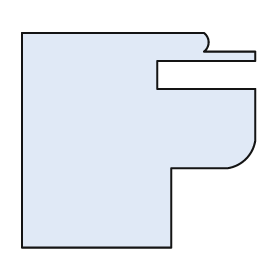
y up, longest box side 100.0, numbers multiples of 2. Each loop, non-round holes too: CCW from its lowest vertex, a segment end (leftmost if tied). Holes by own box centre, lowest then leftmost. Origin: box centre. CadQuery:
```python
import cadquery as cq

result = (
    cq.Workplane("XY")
    .moveTo(-50.0, -46.0)
    .lineTo(14.0, -46.0)
    .lineTo(14.0, -12.0)
    .lineTo(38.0, -12.0)
    .threePointArc((46.0, -8.0), (50.0, 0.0))
    .lineTo(50.0, 22.0)
    .lineTo(8.0, 22.0)
    .lineTo(8.0, 34.0)
    .lineTo(50.0, 34.0)
    .lineTo(50.0, 38.0)
    .lineTo(28.0, 38.0)
    .threePointArc((30.0, 42.0), (28.0, 46.0))
    .lineTo(-50.0, 46.0)
    .close()
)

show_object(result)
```